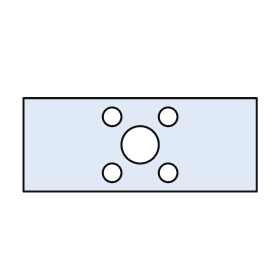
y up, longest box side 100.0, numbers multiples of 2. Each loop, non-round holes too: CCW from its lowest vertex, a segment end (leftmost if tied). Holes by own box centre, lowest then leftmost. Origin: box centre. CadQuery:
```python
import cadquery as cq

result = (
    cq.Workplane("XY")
    .moveTo(-50.0, -20.0)
    .lineTo(50.0, -20.0)
    .lineTo(50.0, 20.0)
    .lineTo(-50.0, 20.0)
    .close()
    .moveTo(-12.0, -12.0)
    .circle(4.0)
    .moveTo(12.0, -12.0)
    .circle(4.0)
    .moveTo(0.0, 0.0)
    .circle(8.0)
    .moveTo(-12.0, 12.0)
    .circle(4.0)
    .moveTo(12.0, 12.0)
    .circle(4.0)
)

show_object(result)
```